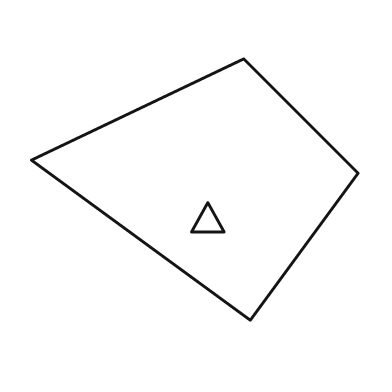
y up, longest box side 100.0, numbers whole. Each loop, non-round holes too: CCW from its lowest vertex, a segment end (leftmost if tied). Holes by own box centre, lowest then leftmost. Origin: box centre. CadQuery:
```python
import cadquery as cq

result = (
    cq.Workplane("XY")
    .moveTo(17.0, -40.0)
    .lineTo(50.0, 5.0)
    .lineTo(15.0, 40.0)
    .lineTo(-50.0, 9.0)
    .close()
    .moveTo(-1.0, -13.0)
    .lineTo(9.0, -13.0)
    .lineTo(4.0, -4.0)
    .close()
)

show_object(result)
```